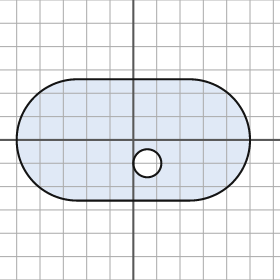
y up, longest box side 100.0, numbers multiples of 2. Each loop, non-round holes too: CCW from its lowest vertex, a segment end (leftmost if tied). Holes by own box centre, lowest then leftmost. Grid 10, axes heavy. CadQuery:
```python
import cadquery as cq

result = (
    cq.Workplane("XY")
    .moveTo(-24.0, -26.0)
    .lineTo(24.0, -26.0)
    .threePointArc((50.0, 0.0), (24.0, 26.0))
    .lineTo(-24.0, 26.0)
    .threePointArc((-50.0, 0.0), (-24.0, -26.0))
    .close()
    .moveTo(6.0, -10.0)
    .circle(6.0)
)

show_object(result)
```